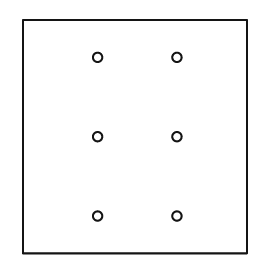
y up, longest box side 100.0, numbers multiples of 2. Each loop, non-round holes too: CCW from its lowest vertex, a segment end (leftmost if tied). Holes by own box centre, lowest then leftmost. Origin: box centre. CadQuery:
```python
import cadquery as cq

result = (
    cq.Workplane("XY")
    .moveTo(-48.0, -50.0)
    .lineTo(48.0, -50.0)
    .lineTo(48.0, 50.0)
    .lineTo(-48.0, 50.0)
    .close()
    .moveTo(-16.0, -34.0)
    .circle(2.0)
    .moveTo(18.0, -34.0)
    .circle(2.0)
    .moveTo(-16.0, 0.0)
    .circle(2.0)
    .moveTo(18.0, 0.0)
    .circle(2.0)
    .moveTo(-16.0, 34.0)
    .circle(2.0)
    .moveTo(18.0, 34.0)
    .circle(2.0)
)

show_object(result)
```